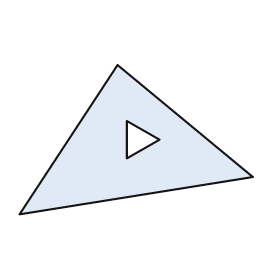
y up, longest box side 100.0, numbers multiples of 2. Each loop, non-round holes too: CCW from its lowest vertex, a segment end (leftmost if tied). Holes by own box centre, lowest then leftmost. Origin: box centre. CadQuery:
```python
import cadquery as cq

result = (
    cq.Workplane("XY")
    .moveTo(-50.0, -32.0)
    .lineTo(50.0, -16.0)
    .lineTo(-8.0, 32.0)
    .close()
    .moveTo(-4.0, -8.0)
    .lineTo(10.0, 0.0)
    .lineTo(-4.0, 8.0)
    .close()
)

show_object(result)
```